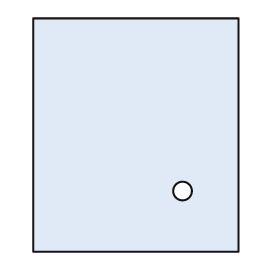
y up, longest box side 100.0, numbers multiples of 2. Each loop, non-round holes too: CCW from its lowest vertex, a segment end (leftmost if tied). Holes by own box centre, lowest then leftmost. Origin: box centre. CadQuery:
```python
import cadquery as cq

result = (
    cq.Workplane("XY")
    .moveTo(-44.0, -50.0)
    .lineTo(44.0, -50.0)
    .lineTo(44.0, 50.0)
    .lineTo(-44.0, 50.0)
    .close()
    .moveTo(20.0, -24.0)
    .circle(4.0)
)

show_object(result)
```